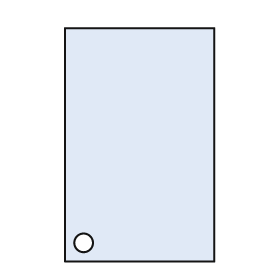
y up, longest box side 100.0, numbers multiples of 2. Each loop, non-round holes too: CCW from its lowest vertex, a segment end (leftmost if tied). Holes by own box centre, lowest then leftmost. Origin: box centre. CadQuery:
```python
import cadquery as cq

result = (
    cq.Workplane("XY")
    .moveTo(-32.0, -50.0)
    .lineTo(32.0, -50.0)
    .lineTo(32.0, 50.0)
    .lineTo(-32.0, 50.0)
    .close()
    .moveTo(-24.0, -42.0)
    .circle(4.0)
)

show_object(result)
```